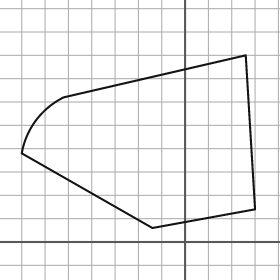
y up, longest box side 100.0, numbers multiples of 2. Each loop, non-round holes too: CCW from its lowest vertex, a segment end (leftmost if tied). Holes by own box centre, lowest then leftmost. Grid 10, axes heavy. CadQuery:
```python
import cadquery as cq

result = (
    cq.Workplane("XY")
    .moveTo(-14.0, 6.0)
    .lineTo(30.0, 14.0)
    .lineTo(26.0, 80.0)
    .lineTo(-52.0, 62.0)
    .threePointArc((-64.0, 52.0), (-70.0, 38.0))
    .close()
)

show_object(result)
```